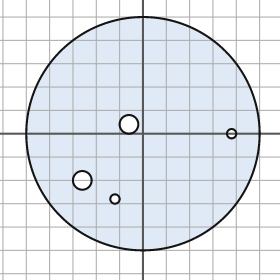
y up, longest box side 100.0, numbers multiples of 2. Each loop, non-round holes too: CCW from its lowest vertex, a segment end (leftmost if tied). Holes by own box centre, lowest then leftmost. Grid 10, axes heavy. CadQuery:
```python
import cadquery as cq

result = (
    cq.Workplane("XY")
    .moveTo(0.0, 0.0)
    .circle(50.0)
    .moveTo(-12.0, -28.0)
    .circle(2.0)
    .moveTo(-26.0, -20.0)
    .circle(4.0)
    .moveTo(38.0, 0.0)
    .circle(2.0)
    .moveTo(-6.0, 4.0)
    .circle(4.0)
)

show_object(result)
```